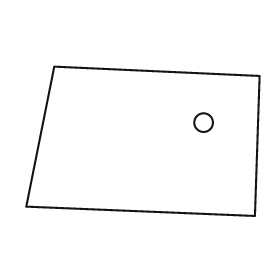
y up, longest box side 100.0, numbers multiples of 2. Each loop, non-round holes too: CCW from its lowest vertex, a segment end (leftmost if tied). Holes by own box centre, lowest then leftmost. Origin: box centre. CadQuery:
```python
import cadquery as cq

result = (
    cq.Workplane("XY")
    .moveTo(48.0, -32.0)
    .lineTo(50.0, 28.0)
    .lineTo(-38.0, 32.0)
    .lineTo(-50.0, -28.0)
    .close()
    .moveTo(26.0, 8.0)
    .circle(4.0)
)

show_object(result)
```